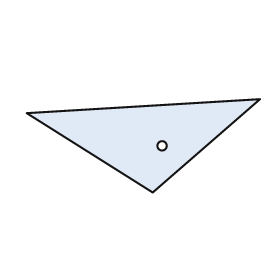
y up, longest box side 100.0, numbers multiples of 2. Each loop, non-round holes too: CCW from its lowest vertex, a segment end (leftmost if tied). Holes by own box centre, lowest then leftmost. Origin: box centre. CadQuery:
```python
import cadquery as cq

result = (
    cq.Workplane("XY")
    .moveTo(4.0, -20.0)
    .lineTo(50.0, 20.0)
    .lineTo(-50.0, 14.0)
    .close()
    .moveTo(8.0, 0.0)
    .circle(2.0)
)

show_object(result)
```